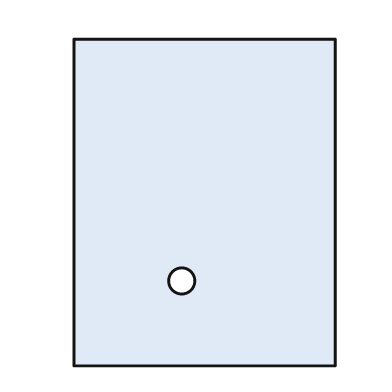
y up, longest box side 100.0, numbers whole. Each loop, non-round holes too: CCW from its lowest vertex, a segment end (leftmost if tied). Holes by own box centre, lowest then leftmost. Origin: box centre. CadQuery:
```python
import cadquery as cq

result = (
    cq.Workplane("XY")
    .moveTo(-40.0, -50.0)
    .lineTo(40.0, -50.0)
    .lineTo(40.0, 50.0)
    .lineTo(-40.0, 50.0)
    .close()
    .moveTo(-7.0, -24.0)
    .circle(4.0)
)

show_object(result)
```